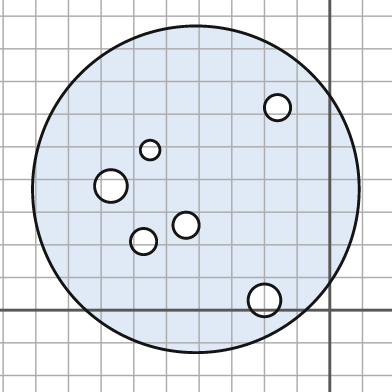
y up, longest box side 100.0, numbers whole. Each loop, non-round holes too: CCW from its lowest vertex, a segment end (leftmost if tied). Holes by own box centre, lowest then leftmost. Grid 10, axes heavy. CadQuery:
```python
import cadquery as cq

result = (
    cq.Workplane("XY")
    .moveTo(-41.0, 37.0)
    .circle(50.0)
    .moveTo(-20.0, 3.0)
    .circle(5.0)
    .moveTo(-57.0, 21.0)
    .circle(4.0)
    .moveTo(-44.0, 26.0)
    .circle(4.0)
    .moveTo(-67.0, 38.0)
    .circle(5.0)
    .moveTo(-55.0, 49.0)
    .circle(3.0)
    .moveTo(-16.0, 62.0)
    .circle(4.0)
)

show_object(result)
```